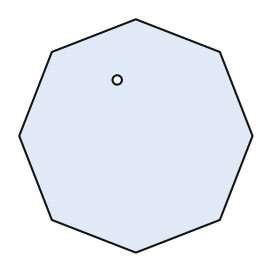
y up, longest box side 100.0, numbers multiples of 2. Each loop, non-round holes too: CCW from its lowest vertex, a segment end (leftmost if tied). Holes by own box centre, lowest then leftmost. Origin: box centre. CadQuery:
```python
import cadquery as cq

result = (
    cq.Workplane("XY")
    .moveTo(0.0, -50.0)
    .lineTo(36.0, -36.0)
    .lineTo(50.0, 0.0)
    .lineTo(36.0, 36.0)
    .lineTo(0.0, 50.0)
    .lineTo(-36.0, 36.0)
    .lineTo(-50.0, 0.0)
    .lineTo(-36.0, -36.0)
    .close()
    .moveTo(-8.0, 24.0)
    .circle(2.0)
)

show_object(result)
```